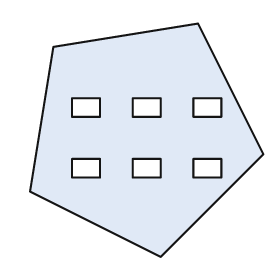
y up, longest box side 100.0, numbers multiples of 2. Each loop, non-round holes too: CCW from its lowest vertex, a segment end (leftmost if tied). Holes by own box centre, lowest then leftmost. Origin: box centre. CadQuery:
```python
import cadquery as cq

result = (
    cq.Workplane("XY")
    .moveTo(6.0, -50.0)
    .lineTo(50.0, -6.0)
    .lineTo(22.0, 50.0)
    .lineTo(-40.0, 40.0)
    .lineTo(-50.0, -22.0)
    .close()
    .moveTo(-32.0, -16.0)
    .lineTo(-20.0, -16.0)
    .lineTo(-20.0, -8.0)
    .lineTo(-32.0, -8.0)
    .close()
    .moveTo(-6.0, -16.0)
    .lineTo(6.0, -16.0)
    .lineTo(6.0, -8.0)
    .lineTo(-6.0, -8.0)
    .close()
    .moveTo(20.0, -16.0)
    .lineTo(32.0, -16.0)
    .lineTo(32.0, -8.0)
    .lineTo(20.0, -8.0)
    .close()
    .moveTo(-32.0, 10.0)
    .lineTo(-20.0, 10.0)
    .lineTo(-20.0, 18.0)
    .lineTo(-32.0, 18.0)
    .close()
    .moveTo(-6.0, 10.0)
    .lineTo(6.0, 10.0)
    .lineTo(6.0, 18.0)
    .lineTo(-6.0, 18.0)
    .close()
    .moveTo(20.0, 10.0)
    .lineTo(32.0, 10.0)
    .lineTo(32.0, 18.0)
    .lineTo(20.0, 18.0)
    .close()
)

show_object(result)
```